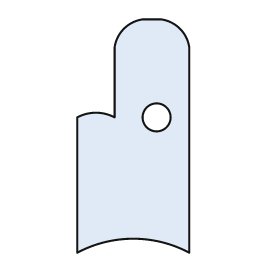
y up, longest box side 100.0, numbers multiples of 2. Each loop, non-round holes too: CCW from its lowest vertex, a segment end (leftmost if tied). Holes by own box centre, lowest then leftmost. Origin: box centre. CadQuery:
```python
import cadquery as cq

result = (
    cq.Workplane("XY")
    .moveTo(-24.0, -50.0)
    .threePointArc((0.0, -44.0), (24.0, -50.0))
    .lineTo(24.0, 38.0)
    .threePointArc((20.0, 46.0), (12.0, 50.0))
    .lineTo(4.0, 50.0)
    .threePointArc((-4.0, 46.0), (-8.0, 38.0))
    .lineTo(-8.0, 8.0)
    .threePointArc((-16.0, 10.0), (-24.0, 8.0))
    .close()
    .moveTo(10.0, 8.0)
    .circle(6.0)
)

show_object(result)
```